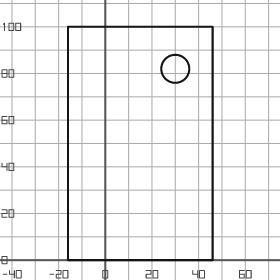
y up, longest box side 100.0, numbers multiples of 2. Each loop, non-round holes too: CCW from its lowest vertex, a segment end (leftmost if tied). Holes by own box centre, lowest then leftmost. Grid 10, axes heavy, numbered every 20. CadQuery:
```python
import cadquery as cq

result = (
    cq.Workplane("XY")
    .moveTo(-16.0, 0.0)
    .lineTo(46.0, 0.0)
    .lineTo(46.0, 100.0)
    .lineTo(-16.0, 100.0)
    .close()
    .moveTo(30.0, 82.0)
    .circle(6.0)
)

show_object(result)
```